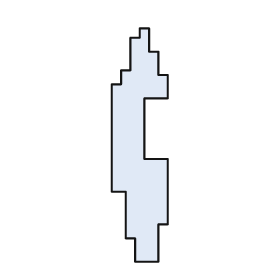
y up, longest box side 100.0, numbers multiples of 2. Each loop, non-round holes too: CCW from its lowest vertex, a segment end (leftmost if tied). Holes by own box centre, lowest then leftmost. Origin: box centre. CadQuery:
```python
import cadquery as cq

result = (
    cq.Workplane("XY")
    .moveTo(-2.0, -50.0)
    .lineTo(8.0, -50.0)
    .lineTo(8.0, -34.0)
    .lineTo(12.0, -34.0)
    .lineTo(12.0, -6.0)
    .lineTo(2.0, -6.0)
    .lineTo(2.0, 20.0)
    .lineTo(12.0, 20.0)
    .lineTo(12.0, 30.0)
    .lineTo(8.0, 30.0)
    .lineTo(8.0, 40.0)
    .lineTo(4.0, 40.0)
    .lineTo(4.0, 50.0)
    .lineTo(0.0, 50.0)
    .lineTo(0.0, 46.0)
    .lineTo(-4.0, 46.0)
    .lineTo(-4.0, 32.0)
    .lineTo(-8.0, 32.0)
    .lineTo(-8.0, 26.0)
    .lineTo(-12.0, 26.0)
    .lineTo(-12.0, -20.0)
    .lineTo(-6.0, -20.0)
    .lineTo(-6.0, -40.0)
    .lineTo(-2.0, -40.0)
    .close()
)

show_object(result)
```